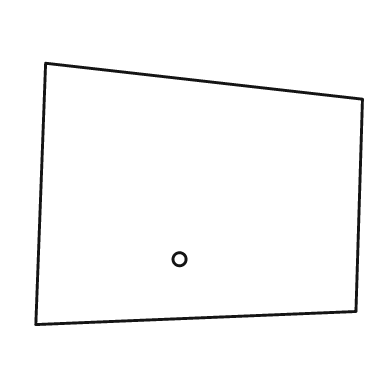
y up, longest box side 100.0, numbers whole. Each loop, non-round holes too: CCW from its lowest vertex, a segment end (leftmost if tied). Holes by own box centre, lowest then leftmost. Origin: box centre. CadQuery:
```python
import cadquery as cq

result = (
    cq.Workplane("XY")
    .moveTo(-50.0, -40.0)
    .lineTo(48.0, -36.0)
    .lineTo(50.0, 29.0)
    .lineTo(-47.0, 40.0)
    .close()
    .moveTo(-6.0, -20.0)
    .circle(2.0)
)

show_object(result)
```